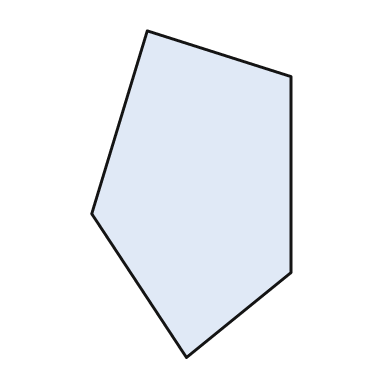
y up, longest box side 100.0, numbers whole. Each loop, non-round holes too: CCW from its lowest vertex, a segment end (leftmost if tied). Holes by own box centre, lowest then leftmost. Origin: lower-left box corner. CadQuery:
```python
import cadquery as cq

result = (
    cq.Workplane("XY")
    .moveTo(29.0, 0.0)
    .lineTo(61.0, 26.0)
    .lineTo(61.0, 86.0)
    .lineTo(17.0, 100.0)
    .lineTo(0.0, 44.0)
    .close()
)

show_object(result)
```